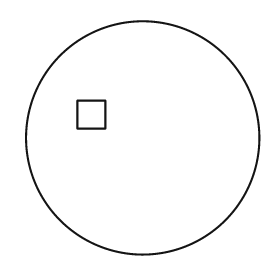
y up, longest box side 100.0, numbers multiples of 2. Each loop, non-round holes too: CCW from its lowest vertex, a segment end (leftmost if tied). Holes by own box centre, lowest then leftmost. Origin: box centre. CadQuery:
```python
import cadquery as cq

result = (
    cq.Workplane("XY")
    .moveTo(0.0, 0.0)
    .circle(50.0)
    .moveTo(-28.0, 4.0)
    .lineTo(-16.0, 4.0)
    .lineTo(-16.0, 16.0)
    .lineTo(-28.0, 16.0)
    .close()
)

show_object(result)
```